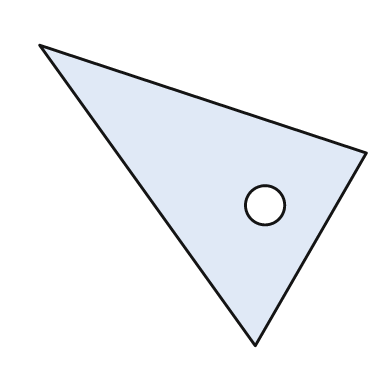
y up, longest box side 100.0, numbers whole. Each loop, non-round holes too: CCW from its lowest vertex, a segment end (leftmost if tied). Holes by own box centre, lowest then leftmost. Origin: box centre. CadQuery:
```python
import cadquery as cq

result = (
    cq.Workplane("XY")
    .moveTo(16.0, -46.0)
    .lineTo(50.0, 13.0)
    .lineTo(-50.0, 46.0)
    .close()
    .moveTo(19.0, -3.0)
    .circle(6.0)
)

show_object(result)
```